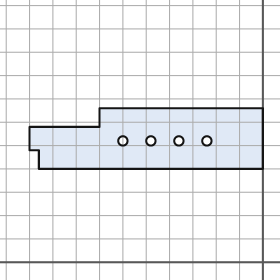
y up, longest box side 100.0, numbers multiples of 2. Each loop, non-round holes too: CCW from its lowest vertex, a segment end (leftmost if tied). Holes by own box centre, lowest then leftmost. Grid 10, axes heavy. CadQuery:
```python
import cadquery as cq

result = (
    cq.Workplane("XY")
    .moveTo(-96.0, 40.0)
    .lineTo(0.0, 40.0)
    .lineTo(0.0, 66.0)
    .lineTo(-70.0, 66.0)
    .lineTo(-70.0, 58.0)
    .lineTo(-100.0, 58.0)
    .lineTo(-100.0, 48.0)
    .lineTo(-96.0, 48.0)
    .close()
    .moveTo(-60.0, 52.0)
    .circle(2.0)
    .moveTo(-48.0, 52.0)
    .circle(2.0)
    .moveTo(-36.0, 52.0)
    .circle(2.0)
    .moveTo(-24.0, 52.0)
    .circle(2.0)
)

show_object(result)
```